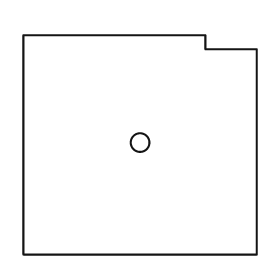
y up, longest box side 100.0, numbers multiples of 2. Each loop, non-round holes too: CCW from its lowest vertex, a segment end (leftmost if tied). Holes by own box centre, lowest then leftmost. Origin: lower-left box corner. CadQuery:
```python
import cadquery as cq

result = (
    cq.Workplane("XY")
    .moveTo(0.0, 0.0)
    .lineTo(100.0, 0.0)
    .lineTo(100.0, 88.0)
    .lineTo(78.0, 88.0)
    .lineTo(78.0, 94.0)
    .lineTo(0.0, 94.0)
    .close()
    .moveTo(50.0, 48.0)
    .circle(4.0)
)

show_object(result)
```